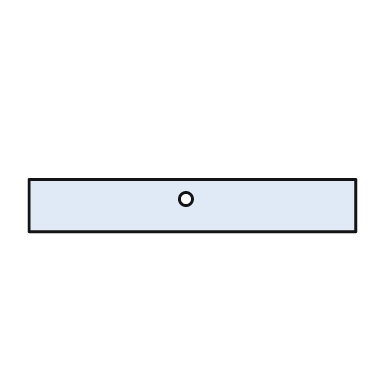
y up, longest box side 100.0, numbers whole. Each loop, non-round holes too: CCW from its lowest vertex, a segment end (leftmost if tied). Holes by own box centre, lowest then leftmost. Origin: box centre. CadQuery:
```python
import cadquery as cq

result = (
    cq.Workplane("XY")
    .moveTo(-50.0, -8.0)
    .lineTo(50.0, -8.0)
    .lineTo(50.0, 8.0)
    .lineTo(-50.0, 8.0)
    .close()
    .moveTo(-2.0, 2.0)
    .circle(2.0)
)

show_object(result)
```